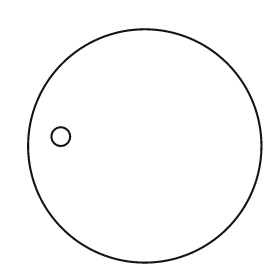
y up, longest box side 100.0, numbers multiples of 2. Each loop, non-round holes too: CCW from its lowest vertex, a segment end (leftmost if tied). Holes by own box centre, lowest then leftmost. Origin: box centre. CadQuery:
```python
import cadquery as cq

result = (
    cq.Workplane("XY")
    .moveTo(0.0, 0.0)
    .circle(50.0)
    .moveTo(-36.0, 4.0)
    .circle(4.0)
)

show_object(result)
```